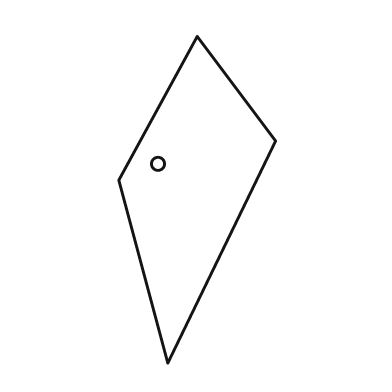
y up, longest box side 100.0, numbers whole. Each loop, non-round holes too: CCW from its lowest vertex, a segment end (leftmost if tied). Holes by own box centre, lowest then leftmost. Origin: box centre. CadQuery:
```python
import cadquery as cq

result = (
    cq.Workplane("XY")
    .moveTo(-9.0, -50.0)
    .lineTo(24.0, 18.0)
    .lineTo(0.0, 50.0)
    .lineTo(-24.0, 6.0)
    .close()
    .moveTo(-12.0, 11.0)
    .circle(2.0)
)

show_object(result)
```